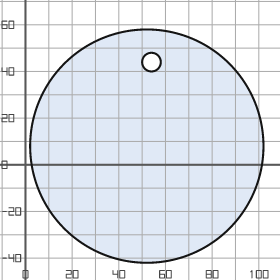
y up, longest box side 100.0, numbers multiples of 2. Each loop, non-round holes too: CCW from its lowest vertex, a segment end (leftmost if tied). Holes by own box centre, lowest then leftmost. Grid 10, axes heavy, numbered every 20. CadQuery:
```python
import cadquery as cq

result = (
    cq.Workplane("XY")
    .moveTo(52.0, 8.0)
    .circle(50.0)
    .moveTo(54.0, 44.0)
    .circle(4.0)
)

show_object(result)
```